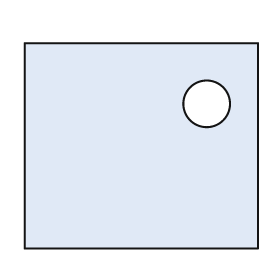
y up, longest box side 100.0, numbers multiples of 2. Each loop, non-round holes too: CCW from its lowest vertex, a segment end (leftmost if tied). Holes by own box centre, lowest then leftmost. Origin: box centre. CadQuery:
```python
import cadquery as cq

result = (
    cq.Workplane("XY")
    .moveTo(-50.0, -44.0)
    .lineTo(50.0, -44.0)
    .lineTo(50.0, 44.0)
    .lineTo(-50.0, 44.0)
    .close()
    .moveTo(28.0, 18.0)
    .circle(10.0)
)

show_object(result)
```